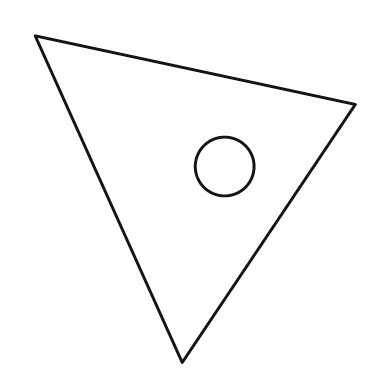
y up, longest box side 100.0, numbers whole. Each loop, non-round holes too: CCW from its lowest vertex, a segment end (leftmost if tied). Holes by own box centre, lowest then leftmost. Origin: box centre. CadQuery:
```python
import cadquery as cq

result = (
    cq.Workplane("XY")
    .moveTo(-4.0, -50.0)
    .lineTo(49.0, 29.0)
    .lineTo(-49.0, 50.0)
    .close()
    .moveTo(9.0, 10.0)
    .circle(9.0)
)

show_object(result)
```